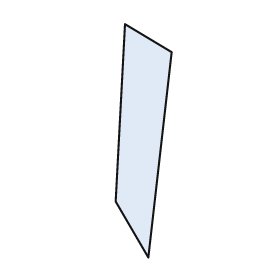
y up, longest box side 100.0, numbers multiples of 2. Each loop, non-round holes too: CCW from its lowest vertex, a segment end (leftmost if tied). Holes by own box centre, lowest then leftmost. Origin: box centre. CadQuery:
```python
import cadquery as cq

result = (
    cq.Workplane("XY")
    .moveTo(2.0, -50.0)
    .lineTo(12.0, 38.0)
    .lineTo(-8.0, 50.0)
    .lineTo(-12.0, -26.0)
    .close()
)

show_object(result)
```